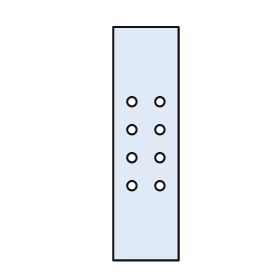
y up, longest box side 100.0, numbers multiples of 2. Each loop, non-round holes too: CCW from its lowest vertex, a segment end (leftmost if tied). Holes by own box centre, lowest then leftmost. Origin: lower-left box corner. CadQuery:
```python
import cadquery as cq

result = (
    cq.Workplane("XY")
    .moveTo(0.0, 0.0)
    .lineTo(28.0, 0.0)
    .lineTo(28.0, 100.0)
    .lineTo(0.0, 100.0)
    .close()
    .moveTo(8.0, 32.0)
    .circle(2.0)
    .moveTo(20.0, 32.0)
    .circle(2.0)
    .moveTo(8.0, 44.0)
    .circle(2.0)
    .moveTo(20.0, 44.0)
    .circle(2.0)
    .moveTo(8.0, 56.0)
    .circle(2.0)
    .moveTo(20.0, 56.0)
    .circle(2.0)
    .moveTo(8.0, 68.0)
    .circle(2.0)
    .moveTo(20.0, 68.0)
    .circle(2.0)
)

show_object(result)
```